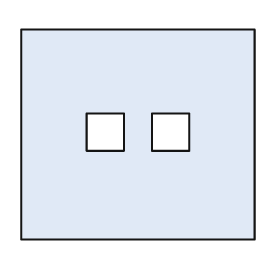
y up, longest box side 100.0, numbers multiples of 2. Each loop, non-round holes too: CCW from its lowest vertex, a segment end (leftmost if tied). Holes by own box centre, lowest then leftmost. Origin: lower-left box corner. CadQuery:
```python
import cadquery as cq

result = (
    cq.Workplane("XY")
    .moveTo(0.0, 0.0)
    .lineTo(100.0, 0.0)
    .lineTo(100.0, 90.0)
    .lineTo(0.0, 90.0)
    .close()
    .moveTo(28.0, 38.0)
    .lineTo(44.0, 38.0)
    .lineTo(44.0, 54.0)
    .lineTo(28.0, 54.0)
    .close()
    .moveTo(56.0, 38.0)
    .lineTo(72.0, 38.0)
    .lineTo(72.0, 54.0)
    .lineTo(56.0, 54.0)
    .close()
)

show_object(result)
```